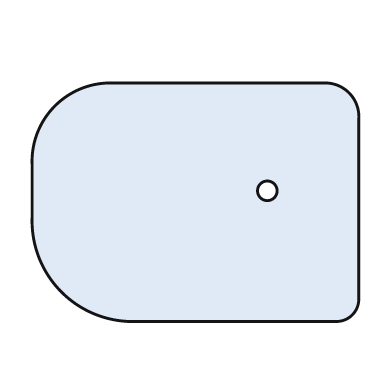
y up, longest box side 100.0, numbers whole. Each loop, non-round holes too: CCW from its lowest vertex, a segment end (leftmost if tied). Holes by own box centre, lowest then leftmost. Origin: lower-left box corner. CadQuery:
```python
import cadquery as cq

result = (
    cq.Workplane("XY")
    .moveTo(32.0, 0.0)
    .lineTo(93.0, 0.0)
    .threePointArc((98.0, 2.0), (100.0, 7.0))
    .lineTo(100.0, 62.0)
    .threePointArc((97.0, 70.0), (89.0, 73.0))
    .lineTo(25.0, 73.0)
    .threePointArc((7.0, 66.0), (0.0, 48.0))
    .lineTo(0.0, 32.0)
    .threePointArc((9.0, 9.0), (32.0, 0.0))
    .close()
    .moveTo(72.0, 40.0)
    .circle(3.0)
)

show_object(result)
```